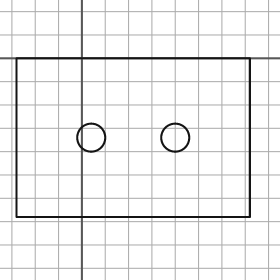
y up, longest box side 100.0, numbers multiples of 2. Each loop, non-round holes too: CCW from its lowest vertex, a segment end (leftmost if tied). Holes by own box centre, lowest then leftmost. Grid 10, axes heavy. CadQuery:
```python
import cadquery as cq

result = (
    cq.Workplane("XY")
    .moveTo(-28.0, -68.0)
    .lineTo(72.0, -68.0)
    .lineTo(72.0, 0.0)
    .lineTo(-28.0, 0.0)
    .close()
    .moveTo(4.0, -34.0)
    .circle(6.0)
    .moveTo(40.0, -34.0)
    .circle(6.0)
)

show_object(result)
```